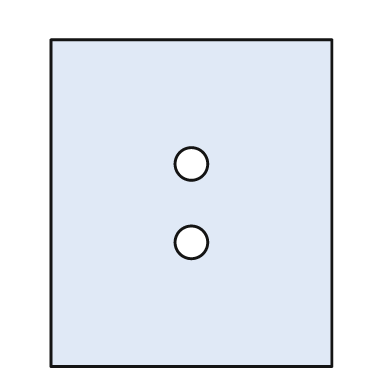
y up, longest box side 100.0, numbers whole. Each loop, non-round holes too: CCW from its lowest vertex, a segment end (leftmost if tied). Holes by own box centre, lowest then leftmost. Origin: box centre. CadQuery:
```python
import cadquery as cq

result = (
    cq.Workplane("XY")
    .moveTo(-43.0, -50.0)
    .lineTo(43.0, -50.0)
    .lineTo(43.0, 50.0)
    .lineTo(-43.0, 50.0)
    .close()
    .moveTo(0.0, -12.0)
    .circle(5.0)
    .moveTo(0.0, 12.0)
    .circle(5.0)
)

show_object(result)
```